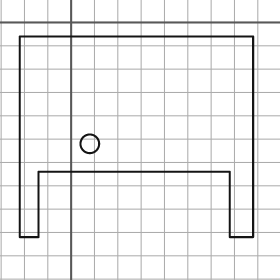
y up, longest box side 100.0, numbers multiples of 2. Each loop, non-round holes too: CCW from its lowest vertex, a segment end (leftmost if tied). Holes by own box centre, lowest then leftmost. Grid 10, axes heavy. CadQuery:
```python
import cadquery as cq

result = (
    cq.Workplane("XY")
    .moveTo(-22.0, -92.0)
    .lineTo(-14.0, -92.0)
    .lineTo(-14.0, -64.0)
    .lineTo(68.0, -64.0)
    .lineTo(68.0, -92.0)
    .lineTo(78.0, -92.0)
    .lineTo(78.0, -6.0)
    .lineTo(-22.0, -6.0)
    .close()
    .moveTo(8.0, -52.0)
    .circle(4.0)
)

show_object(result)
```